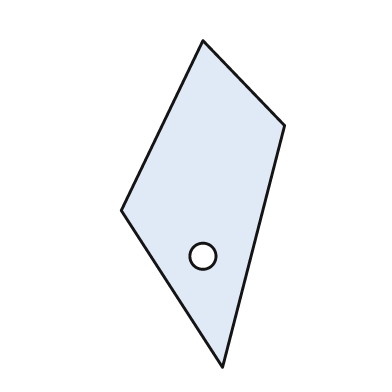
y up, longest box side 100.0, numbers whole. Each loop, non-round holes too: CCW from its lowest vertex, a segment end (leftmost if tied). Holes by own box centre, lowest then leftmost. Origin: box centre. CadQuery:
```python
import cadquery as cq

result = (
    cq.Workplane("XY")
    .moveTo(6.0, -50.0)
    .lineTo(25.0, 24.0)
    .lineTo(0.0, 50.0)
    .lineTo(-25.0, -2.0)
    .close()
    .moveTo(0.0, -16.0)
    .circle(4.0)
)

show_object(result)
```